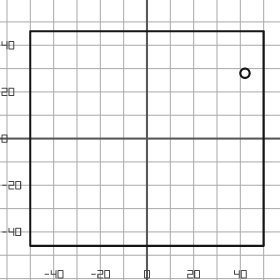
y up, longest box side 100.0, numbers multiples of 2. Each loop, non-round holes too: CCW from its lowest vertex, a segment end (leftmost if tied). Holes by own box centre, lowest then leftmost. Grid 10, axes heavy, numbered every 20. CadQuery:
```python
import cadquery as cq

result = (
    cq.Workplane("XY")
    .moveTo(-50.0, -46.0)
    .lineTo(50.0, -46.0)
    .lineTo(50.0, 46.0)
    .lineTo(-50.0, 46.0)
    .close()
    .moveTo(42.0, 28.0)
    .circle(2.0)
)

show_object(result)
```